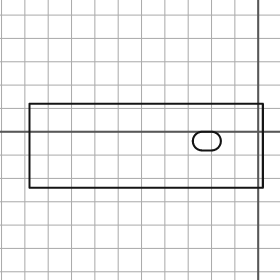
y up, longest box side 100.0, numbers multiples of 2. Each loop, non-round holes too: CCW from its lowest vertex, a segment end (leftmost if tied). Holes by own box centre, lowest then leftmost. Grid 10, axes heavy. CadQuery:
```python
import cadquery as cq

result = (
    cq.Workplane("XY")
    .moveTo(-98.0, -24.0)
    .lineTo(2.0, -24.0)
    .lineTo(2.0, 12.0)
    .lineTo(-98.0, 12.0)
    .close()
    .moveTo(-24.0, -8.0)
    .lineTo(-20.0, -8.0)
    .threePointArc((-16.0, -4.0), (-20.0, 0.0))
    .lineTo(-24.0, 0.0)
    .threePointArc((-28.0, -4.0), (-24.0, -8.0))
    .close()
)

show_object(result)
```